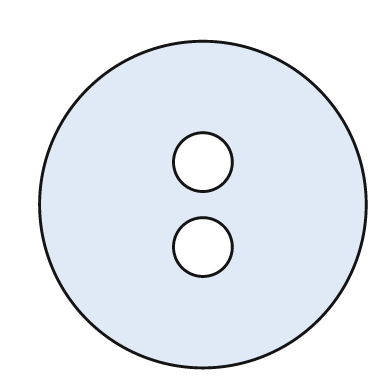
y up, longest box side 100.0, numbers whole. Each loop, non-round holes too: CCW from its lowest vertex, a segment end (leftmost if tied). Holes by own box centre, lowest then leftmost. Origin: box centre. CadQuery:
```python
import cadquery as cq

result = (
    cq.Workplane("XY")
    .moveTo(0.0, 0.0)
    .circle(50.0)
    .moveTo(0.0, -13.0)
    .circle(9.0)
    .moveTo(0.0, 13.0)
    .circle(9.0)
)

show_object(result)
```